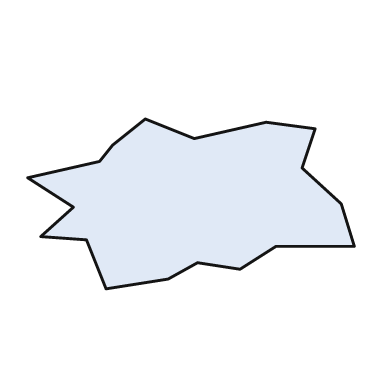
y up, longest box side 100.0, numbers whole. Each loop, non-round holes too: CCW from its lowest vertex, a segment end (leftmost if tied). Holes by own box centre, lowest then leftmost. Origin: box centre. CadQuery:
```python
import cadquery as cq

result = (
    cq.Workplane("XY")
    .moveTo(-26.0, -26.0)
    .lineTo(-7.0, -23.0)
    .lineTo(2.0, -18.0)
    .lineTo(15.0, -20.0)
    .lineTo(26.0, -13.0)
    .lineTo(50.0, -13.0)
    .lineTo(46.0, 0.0)
    .lineTo(34.0, 11.0)
    .lineTo(38.0, 23.0)
    .lineTo(23.0, 25.0)
    .lineTo(1.0, 20.0)
    .lineTo(-14.0, 26.0)
    .lineTo(-24.0, 18.0)
    .lineTo(-28.0, 13.0)
    .lineTo(-50.0, 8.0)
    .lineTo(-36.0, -1.0)
    .lineTo(-46.0, -10.0)
    .lineTo(-32.0, -11.0)
    .close()
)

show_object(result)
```